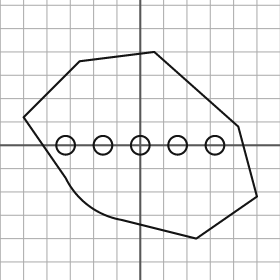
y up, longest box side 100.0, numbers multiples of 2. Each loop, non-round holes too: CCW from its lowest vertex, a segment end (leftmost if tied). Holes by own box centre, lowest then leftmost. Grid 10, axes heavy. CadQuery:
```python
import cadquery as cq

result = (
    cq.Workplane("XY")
    .moveTo(24.0, -40.0)
    .lineTo(50.0, -22.0)
    .lineTo(42.0, 8.0)
    .lineTo(6.0, 40.0)
    .lineTo(-26.0, 36.0)
    .lineTo(-50.0, 12.0)
    .lineTo(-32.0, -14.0)
    .threePointArc((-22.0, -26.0), (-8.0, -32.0))
    .close()
    .moveTo(-32.0, 0.0)
    .circle(4.0)
    .moveTo(-16.0, 0.0)
    .circle(4.0)
    .moveTo(0.0, 0.0)
    .circle(4.0)
    .moveTo(16.0, 0.0)
    .circle(4.0)
    .moveTo(32.0, 0.0)
    .circle(4.0)
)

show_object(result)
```